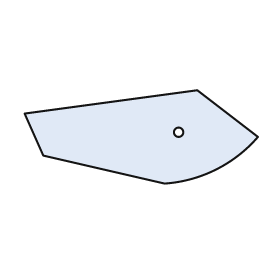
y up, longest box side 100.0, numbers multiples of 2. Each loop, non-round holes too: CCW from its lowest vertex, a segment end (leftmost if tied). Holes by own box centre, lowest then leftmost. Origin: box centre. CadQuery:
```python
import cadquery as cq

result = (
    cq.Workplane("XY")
    .moveTo(10.0, -20.0)
    .threePointArc((32.0, -14.0), (50.0, 0.0))
    .lineTo(24.0, 20.0)
    .lineTo(-50.0, 10.0)
    .lineTo(-42.0, -8.0)
    .close()
    .moveTo(16.0, 2.0)
    .circle(2.0)
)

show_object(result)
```